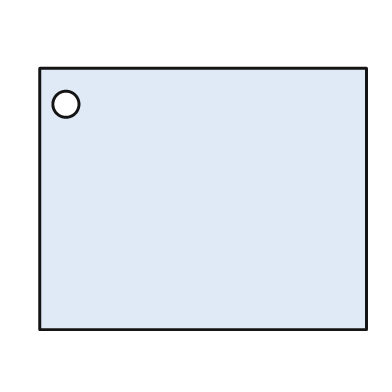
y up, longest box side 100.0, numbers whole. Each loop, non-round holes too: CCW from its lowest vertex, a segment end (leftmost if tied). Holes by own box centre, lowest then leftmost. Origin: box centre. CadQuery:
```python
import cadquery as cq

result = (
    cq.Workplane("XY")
    .moveTo(-50.0, -40.0)
    .lineTo(50.0, -40.0)
    .lineTo(50.0, 40.0)
    .lineTo(-50.0, 40.0)
    .close()
    .moveTo(-42.0, 29.0)
    .circle(4.0)
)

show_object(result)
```